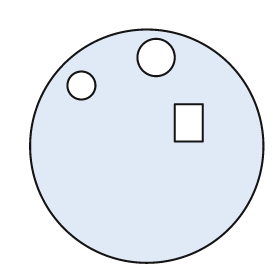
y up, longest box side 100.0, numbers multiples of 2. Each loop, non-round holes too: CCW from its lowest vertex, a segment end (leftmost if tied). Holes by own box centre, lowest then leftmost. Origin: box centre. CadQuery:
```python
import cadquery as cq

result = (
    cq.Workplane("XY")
    .moveTo(0.0, 0.0)
    .circle(50.0)
    .moveTo(12.0, 2.0)
    .lineTo(24.0, 2.0)
    .lineTo(24.0, 18.0)
    .lineTo(12.0, 18.0)
    .close()
    .moveTo(-28.0, 26.0)
    .circle(6.0)
    .moveTo(4.0, 38.0)
    .circle(8.0)
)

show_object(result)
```